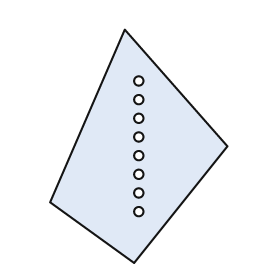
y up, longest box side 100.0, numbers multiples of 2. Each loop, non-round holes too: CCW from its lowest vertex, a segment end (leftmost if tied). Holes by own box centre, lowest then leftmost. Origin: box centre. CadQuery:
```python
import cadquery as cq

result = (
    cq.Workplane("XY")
    .moveTo(-2.0, -50.0)
    .lineTo(38.0, 0.0)
    .lineTo(-6.0, 50.0)
    .lineTo(-38.0, -24.0)
    .close()
    .moveTo(0.0, -28.0)
    .circle(2.0)
    .moveTo(0.0, -20.0)
    .circle(2.0)
    .moveTo(0.0, -12.0)
    .circle(2.0)
    .moveTo(0.0, -4.0)
    .circle(2.0)
    .moveTo(0.0, 4.0)
    .circle(2.0)
    .moveTo(0.0, 12.0)
    .circle(2.0)
    .moveTo(0.0, 20.0)
    .circle(2.0)
    .moveTo(0.0, 28.0)
    .circle(2.0)
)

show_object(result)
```